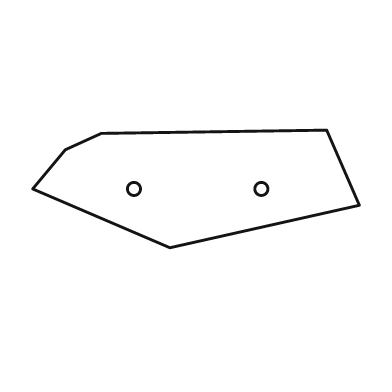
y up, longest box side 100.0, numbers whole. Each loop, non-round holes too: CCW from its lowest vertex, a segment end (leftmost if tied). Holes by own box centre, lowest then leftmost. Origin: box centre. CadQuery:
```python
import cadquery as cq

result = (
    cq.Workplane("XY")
    .moveTo(-8.0, -18.0)
    .lineTo(50.0, -5.0)
    .lineTo(40.0, 18.0)
    .lineTo(-29.0, 17.0)
    .lineTo(-40.0, 12.0)
    .lineTo(-50.0, 0.0)
    .close()
    .moveTo(-19.0, 0.0)
    .circle(2.0)
    .moveTo(20.0, 0.0)
    .circle(2.0)
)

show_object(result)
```